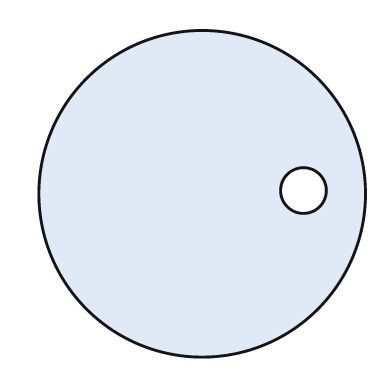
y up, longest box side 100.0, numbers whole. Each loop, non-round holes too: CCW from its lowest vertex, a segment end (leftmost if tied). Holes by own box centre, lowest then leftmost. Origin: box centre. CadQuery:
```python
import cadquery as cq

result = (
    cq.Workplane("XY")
    .moveTo(0.0, 0.0)
    .circle(50.0)
    .moveTo(31.0, 1.0)
    .circle(7.0)
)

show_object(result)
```